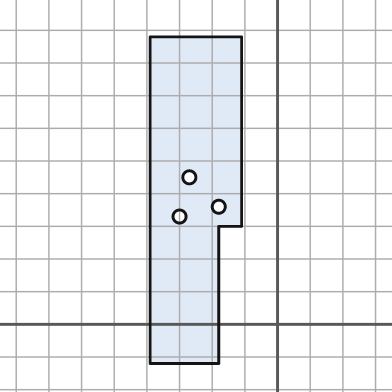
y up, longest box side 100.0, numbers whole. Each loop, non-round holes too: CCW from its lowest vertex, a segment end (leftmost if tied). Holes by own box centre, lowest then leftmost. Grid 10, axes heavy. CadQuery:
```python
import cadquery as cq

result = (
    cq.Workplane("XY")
    .moveTo(-39.0, -12.0)
    .lineTo(-18.0, -12.0)
    .lineTo(-18.0, 30.0)
    .lineTo(-11.0, 30.0)
    .lineTo(-11.0, 88.0)
    .lineTo(-39.0, 88.0)
    .close()
    .moveTo(-30.0, 33.0)
    .circle(2.0)
    .moveTo(-18.0, 36.0)
    .circle(2.0)
    .moveTo(-27.0, 45.0)
    .circle(2.0)
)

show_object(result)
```